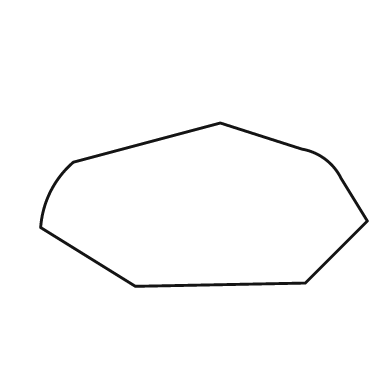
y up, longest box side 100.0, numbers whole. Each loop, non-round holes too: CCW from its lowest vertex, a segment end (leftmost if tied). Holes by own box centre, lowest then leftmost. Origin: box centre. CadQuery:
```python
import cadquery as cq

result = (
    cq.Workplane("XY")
    .moveTo(-21.0, -25.0)
    .lineTo(31.0, -24.0)
    .lineTo(50.0, -5.0)
    .lineTo(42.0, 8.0)
    .threePointArc((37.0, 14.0), (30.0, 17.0))
    .lineTo(5.0, 25.0)
    .lineTo(-40.0, 13.0)
    .threePointArc((-47.0, 4.0), (-50.0, -7.0))
    .close()
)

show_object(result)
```